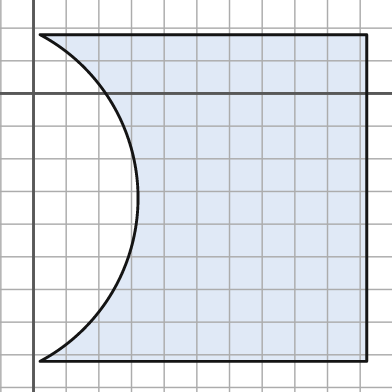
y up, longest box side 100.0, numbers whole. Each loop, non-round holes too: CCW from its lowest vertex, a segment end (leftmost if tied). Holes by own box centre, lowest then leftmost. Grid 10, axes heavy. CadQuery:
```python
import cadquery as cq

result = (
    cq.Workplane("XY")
    .moveTo(2.0, -82.0)
    .lineTo(102.0, -82.0)
    .lineTo(102.0, 18.0)
    .lineTo(2.0, 18.0)
    .threePointArc((32.0, -32.0), (2.0, -82.0))
    .close()
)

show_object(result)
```